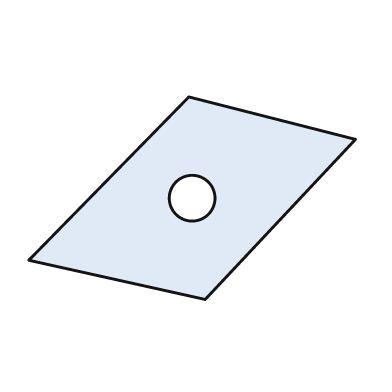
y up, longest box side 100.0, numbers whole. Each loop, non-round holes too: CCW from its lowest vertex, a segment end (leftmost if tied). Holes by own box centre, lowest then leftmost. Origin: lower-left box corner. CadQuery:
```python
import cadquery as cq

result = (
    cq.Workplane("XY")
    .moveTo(54.0, 0.0)
    .lineTo(100.0, 49.0)
    .lineTo(49.0, 62.0)
    .lineTo(0.0, 12.0)
    .close()
    .moveTo(50.0, 31.0)
    .circle(7.0)
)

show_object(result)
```